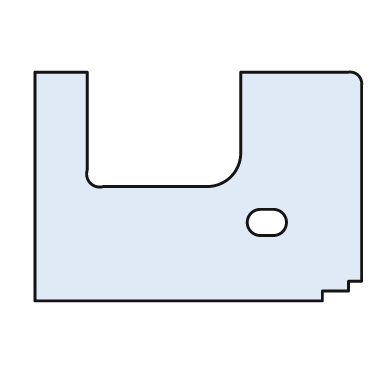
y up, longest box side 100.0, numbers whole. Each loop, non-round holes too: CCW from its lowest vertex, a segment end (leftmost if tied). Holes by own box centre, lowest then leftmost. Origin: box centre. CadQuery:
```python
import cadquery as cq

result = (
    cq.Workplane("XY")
    .moveTo(-50.0, -35.0)
    .lineTo(38.0, -35.0)
    .lineTo(38.0, -32.0)
    .lineTo(46.0, -32.0)
    .lineTo(46.0, -29.0)
    .lineTo(50.0, -29.0)
    .lineTo(50.0, 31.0)
    .threePointArc((49.0, 34.0), (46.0, 35.0))
    .lineTo(13.0, 35.0)
    .lineTo(13.0, 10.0)
    .threePointArc((10.0, 3.0), (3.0, 0.0))
    .lineTo(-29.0, 0.0)
    .threePointArc((-33.0, 1.0), (-34.0, 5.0))
    .lineTo(-34.0, 35.0)
    .lineTo(-50.0, 35.0)
    .close()
    .moveTo(19.0, -15.0)
    .lineTo(23.0, -15.0)
    .threePointArc((27.0, -11.0), (23.0, -7.0))
    .lineTo(19.0, -7.0)
    .threePointArc((15.0, -11.0), (19.0, -15.0))
    .close()
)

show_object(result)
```